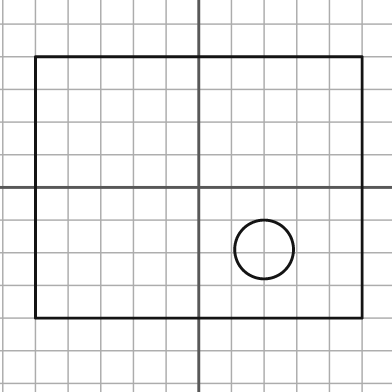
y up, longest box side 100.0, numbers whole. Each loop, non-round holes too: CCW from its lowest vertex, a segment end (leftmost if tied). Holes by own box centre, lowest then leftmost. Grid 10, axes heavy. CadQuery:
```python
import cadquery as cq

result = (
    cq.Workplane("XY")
    .moveTo(-50.0, -40.0)
    .lineTo(50.0, -40.0)
    .lineTo(50.0, 40.0)
    .lineTo(-50.0, 40.0)
    .close()
    .moveTo(20.0, -19.0)
    .circle(9.0)
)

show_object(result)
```